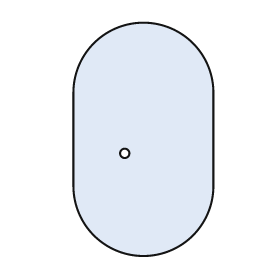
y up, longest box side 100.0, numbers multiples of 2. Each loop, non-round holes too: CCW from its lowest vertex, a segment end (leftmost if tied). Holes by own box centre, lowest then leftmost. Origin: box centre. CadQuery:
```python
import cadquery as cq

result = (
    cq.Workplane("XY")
    .moveTo(-30.0, -20.0)
    .threePointArc((0.0, -50.0), (30.0, -20.0))
    .lineTo(30.0, 20.0)
    .threePointArc((0.0, 50.0), (-30.0, 20.0))
    .close()
    .moveTo(-8.0, -6.0)
    .circle(2.0)
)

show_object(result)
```